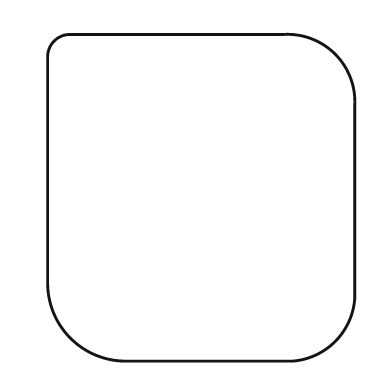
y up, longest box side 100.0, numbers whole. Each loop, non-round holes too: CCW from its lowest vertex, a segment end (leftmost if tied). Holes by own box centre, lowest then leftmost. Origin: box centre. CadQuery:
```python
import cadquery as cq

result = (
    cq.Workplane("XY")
    .moveTo(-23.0, -50.0)
    .lineTo(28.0, -50.0)
    .threePointArc((41.0, -44.0), (47.0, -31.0))
    .lineTo(47.0, 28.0)
    .threePointArc((41.0, 44.0), (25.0, 50.0))
    .lineTo(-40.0, 50.0)
    .threePointArc((-45.0, 48.0), (-47.0, 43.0))
    .lineTo(-47.0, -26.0)
    .threePointArc((-40.0, -43.0), (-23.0, -50.0))
    .close()
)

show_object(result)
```